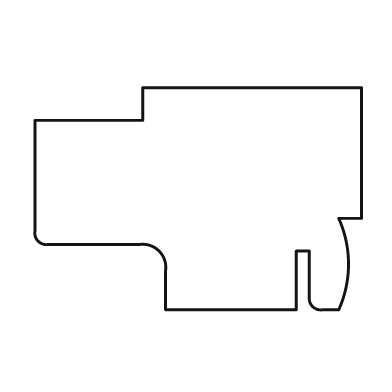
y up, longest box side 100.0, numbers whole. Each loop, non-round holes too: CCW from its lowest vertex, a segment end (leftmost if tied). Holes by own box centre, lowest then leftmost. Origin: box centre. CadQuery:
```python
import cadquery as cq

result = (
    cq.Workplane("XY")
    .moveTo(-10.0, -34.0)
    .lineTo(30.0, -34.0)
    .lineTo(30.0, -16.0)
    .lineTo(34.0, -16.0)
    .lineTo(34.0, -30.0)
    .threePointArc((35.0, -33.0), (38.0, -34.0))
    .lineTo(43.0, -34.0)
    .threePointArc((46.0, -20.0), (43.0, -6.0))
    .lineTo(50.0, -6.0)
    .lineTo(50.0, 34.0)
    .lineTo(-17.0, 34.0)
    .lineTo(-17.0, 24.0)
    .lineTo(-50.0, 24.0)
    .lineTo(-50.0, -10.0)
    .threePointArc((-49.0, -13.0), (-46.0, -14.0))
    .lineTo(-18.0, -14.0)
    .threePointArc((-12.0, -16.0), (-10.0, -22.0))
    .close()
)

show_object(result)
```